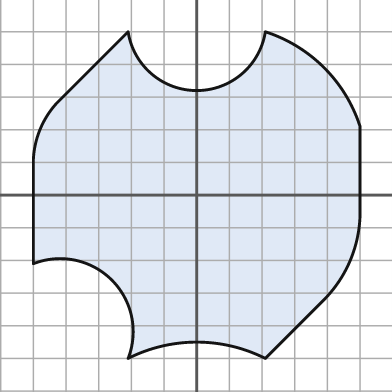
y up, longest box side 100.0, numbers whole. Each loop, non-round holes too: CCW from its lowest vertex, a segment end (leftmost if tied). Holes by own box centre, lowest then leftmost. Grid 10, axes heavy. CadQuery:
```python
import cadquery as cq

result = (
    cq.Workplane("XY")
    .moveTo(-21.0, -50.0)
    .threePointArc((0.0, -45.0), (21.0, -50.0))
    .lineTo(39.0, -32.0)
    .threePointArc((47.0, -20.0), (50.0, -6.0))
    .lineTo(50.0, 21.0)
    .threePointArc((39.0, 39.0), (21.0, 50.0))
    .threePointArc((0.0, 32.0), (-21.0, 50.0))
    .lineTo(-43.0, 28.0)
    .threePointArc((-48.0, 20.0), (-50.0, 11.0))
    .lineTo(-50.0, -21.0)
    .threePointArc((-26.0, -26.0), (-21.0, -50.0))
    .close()
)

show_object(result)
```